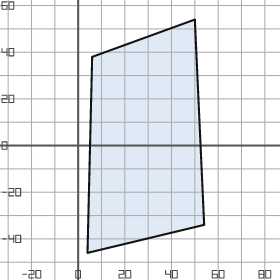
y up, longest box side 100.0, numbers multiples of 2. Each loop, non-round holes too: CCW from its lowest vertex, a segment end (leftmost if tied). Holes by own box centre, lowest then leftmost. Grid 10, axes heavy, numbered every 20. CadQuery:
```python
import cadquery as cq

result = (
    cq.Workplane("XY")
    .moveTo(4.0, -46.0)
    .lineTo(54.0, -34.0)
    .lineTo(50.0, 54.0)
    .lineTo(6.0, 38.0)
    .close()
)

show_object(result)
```